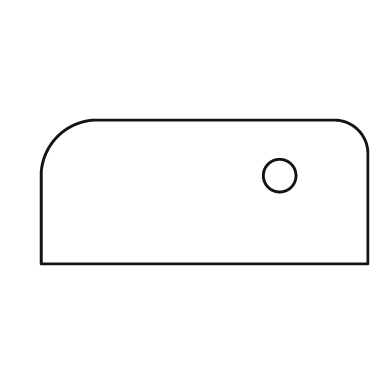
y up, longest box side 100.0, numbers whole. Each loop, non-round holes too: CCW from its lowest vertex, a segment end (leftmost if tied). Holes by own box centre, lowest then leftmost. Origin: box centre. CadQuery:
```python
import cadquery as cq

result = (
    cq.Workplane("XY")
    .moveTo(-50.0, -22.0)
    .lineTo(50.0, -22.0)
    .lineTo(50.0, 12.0)
    .threePointArc((47.0, 19.0), (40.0, 22.0))
    .lineTo(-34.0, 22.0)
    .threePointArc((-45.0, 17.0), (-50.0, 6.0))
    .close()
    .moveTo(23.0, 5.0)
    .circle(5.0)
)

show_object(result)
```